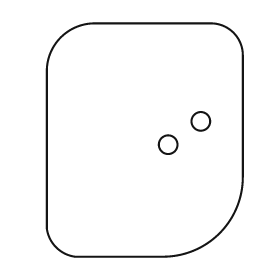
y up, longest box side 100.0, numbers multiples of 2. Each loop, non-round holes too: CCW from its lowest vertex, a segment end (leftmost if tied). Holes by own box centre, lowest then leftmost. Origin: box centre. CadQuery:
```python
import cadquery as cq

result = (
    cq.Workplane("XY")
    .moveTo(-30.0, -50.0)
    .lineTo(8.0, -50.0)
    .threePointArc((32.0, -40.0), (42.0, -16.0))
    .lineTo(42.0, 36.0)
    .threePointArc((38.0, 46.0), (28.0, 50.0))
    .lineTo(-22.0, 50.0)
    .threePointArc((-36.0, 44.0), (-42.0, 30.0))
    .lineTo(-42.0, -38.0)
    .threePointArc((-38.0, -46.0), (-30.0, -50.0))
    .close()
    .moveTo(10.0, -2.0)
    .circle(4.0)
    .moveTo(24.0, 8.0)
    .circle(4.0)
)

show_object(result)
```